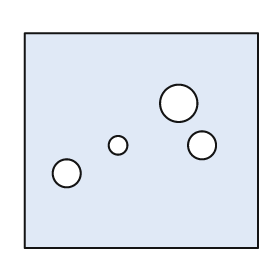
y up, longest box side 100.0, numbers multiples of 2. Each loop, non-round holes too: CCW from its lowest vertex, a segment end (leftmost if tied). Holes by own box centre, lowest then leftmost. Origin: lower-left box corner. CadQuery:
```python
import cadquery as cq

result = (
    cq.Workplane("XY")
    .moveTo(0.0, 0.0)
    .lineTo(100.0, 0.0)
    .lineTo(100.0, 92.0)
    .lineTo(0.0, 92.0)
    .close()
    .moveTo(18.0, 32.0)
    .circle(6.0)
    .moveTo(40.0, 44.0)
    .circle(4.0)
    .moveTo(76.0, 44.0)
    .circle(6.0)
    .moveTo(66.0, 62.0)
    .circle(8.0)
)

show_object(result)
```